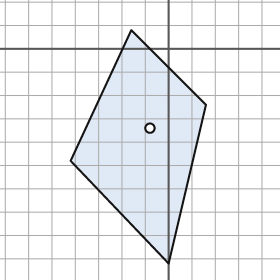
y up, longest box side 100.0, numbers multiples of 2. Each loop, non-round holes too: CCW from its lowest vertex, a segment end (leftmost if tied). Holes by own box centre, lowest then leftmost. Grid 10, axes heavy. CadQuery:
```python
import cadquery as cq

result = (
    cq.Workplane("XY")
    .moveTo(0.0, -92.0)
    .lineTo(16.0, -24.0)
    .lineTo(-16.0, 8.0)
    .lineTo(-42.0, -48.0)
    .close()
    .moveTo(-8.0, -34.0)
    .circle(2.0)
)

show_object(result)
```